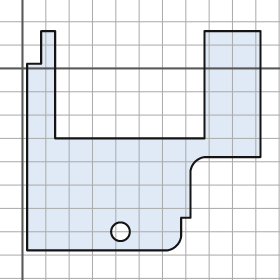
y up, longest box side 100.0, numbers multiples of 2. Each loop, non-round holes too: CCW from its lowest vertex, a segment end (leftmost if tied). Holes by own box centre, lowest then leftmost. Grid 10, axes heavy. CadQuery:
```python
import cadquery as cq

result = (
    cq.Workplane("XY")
    .moveTo(2.0, -78.0)
    .lineTo(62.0, -78.0)
    .threePointArc((66.0, -76.0), (68.0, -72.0))
    .lineTo(68.0, -64.0)
    .lineTo(72.0, -64.0)
    .lineTo(72.0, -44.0)
    .threePointArc((74.0, -40.0), (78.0, -38.0))
    .lineTo(102.0, -38.0)
    .lineTo(102.0, 16.0)
    .lineTo(78.0, 16.0)
    .lineTo(78.0, -30.0)
    .lineTo(14.0, -30.0)
    .lineTo(14.0, 16.0)
    .lineTo(8.0, 16.0)
    .lineTo(8.0, 2.0)
    .lineTo(2.0, 2.0)
    .close()
    .moveTo(42.0, -70.0)
    .circle(4.0)
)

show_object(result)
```